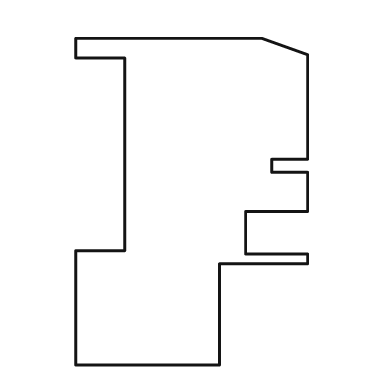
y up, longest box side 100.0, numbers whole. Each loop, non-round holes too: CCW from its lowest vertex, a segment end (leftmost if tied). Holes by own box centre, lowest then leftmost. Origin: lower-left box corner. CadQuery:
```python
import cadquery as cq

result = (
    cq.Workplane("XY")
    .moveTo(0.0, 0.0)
    .lineTo(44.0, 0.0)
    .lineTo(44.0, 31.0)
    .lineTo(71.0, 31.0)
    .lineTo(71.0, 34.0)
    .lineTo(52.0, 34.0)
    .lineTo(52.0, 47.0)
    .lineTo(71.0, 47.0)
    .lineTo(71.0, 59.0)
    .lineTo(60.0, 59.0)
    .lineTo(60.0, 63.0)
    .lineTo(71.0, 63.0)
    .lineTo(71.0, 95.0)
    .lineTo(57.0, 100.0)
    .lineTo(0.0, 100.0)
    .lineTo(0.0, 94.0)
    .lineTo(15.0, 94.0)
    .lineTo(15.0, 35.0)
    .lineTo(0.0, 35.0)
    .close()
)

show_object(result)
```